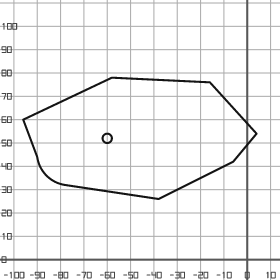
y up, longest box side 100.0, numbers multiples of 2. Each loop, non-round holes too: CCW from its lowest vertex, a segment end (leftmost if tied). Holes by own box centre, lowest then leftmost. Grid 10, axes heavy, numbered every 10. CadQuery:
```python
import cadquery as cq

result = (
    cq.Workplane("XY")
    .moveTo(-38.0, 26.0)
    .lineTo(-6.0, 42.0)
    .lineTo(4.0, 54.0)
    .lineTo(-16.0, 76.0)
    .lineTo(-58.0, 78.0)
    .lineTo(-96.0, 60.0)
    .lineTo(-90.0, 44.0)
    .threePointArc((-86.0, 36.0), (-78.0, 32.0))
    .close()
    .moveTo(-60.0, 52.0)
    .circle(2.0)
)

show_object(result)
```